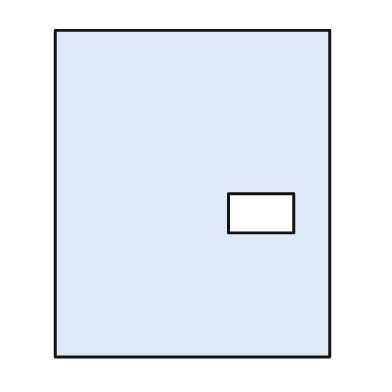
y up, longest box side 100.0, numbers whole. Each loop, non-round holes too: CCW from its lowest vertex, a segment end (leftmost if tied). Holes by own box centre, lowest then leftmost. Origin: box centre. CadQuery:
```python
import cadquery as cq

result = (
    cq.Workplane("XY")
    .moveTo(-42.0, -50.0)
    .lineTo(42.0, -50.0)
    .lineTo(42.0, 50.0)
    .lineTo(-42.0, 50.0)
    .close()
    .moveTo(11.0, -12.0)
    .lineTo(31.0, -12.0)
    .lineTo(31.0, 0.0)
    .lineTo(11.0, 0.0)
    .close()
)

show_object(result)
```